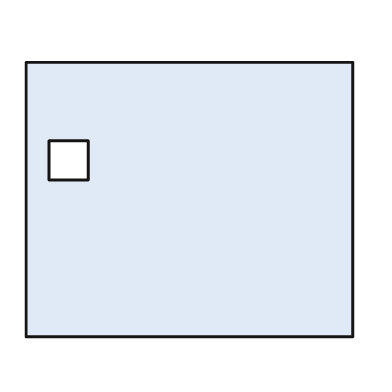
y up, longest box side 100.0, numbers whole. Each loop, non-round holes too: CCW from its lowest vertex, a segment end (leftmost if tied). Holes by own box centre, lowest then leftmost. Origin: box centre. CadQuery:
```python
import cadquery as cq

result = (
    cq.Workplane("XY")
    .moveTo(-50.0, -42.0)
    .lineTo(50.0, -42.0)
    .lineTo(50.0, 42.0)
    .lineTo(-50.0, 42.0)
    .close()
    .moveTo(-43.0, 6.0)
    .lineTo(-31.0, 6.0)
    .lineTo(-31.0, 18.0)
    .lineTo(-43.0, 18.0)
    .close()
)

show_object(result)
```